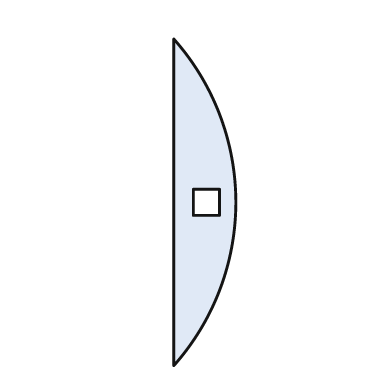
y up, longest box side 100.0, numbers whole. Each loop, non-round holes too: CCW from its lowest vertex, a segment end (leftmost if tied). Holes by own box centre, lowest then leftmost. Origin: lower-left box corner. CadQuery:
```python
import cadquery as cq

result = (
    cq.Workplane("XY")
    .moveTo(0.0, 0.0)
    .threePointArc((19.0, 50.0), (0.0, 100.0))
    .close()
    .moveTo(6.0, 46.0)
    .lineTo(14.0, 46.0)
    .lineTo(14.0, 54.0)
    .lineTo(6.0, 54.0)
    .close()
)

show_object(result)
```